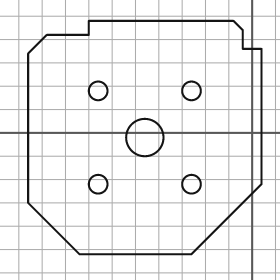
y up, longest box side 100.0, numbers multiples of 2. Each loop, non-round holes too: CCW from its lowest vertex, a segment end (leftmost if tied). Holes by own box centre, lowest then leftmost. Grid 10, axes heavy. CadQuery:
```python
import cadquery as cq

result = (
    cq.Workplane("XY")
    .moveTo(-74.0, -52.0)
    .lineTo(-26.0, -52.0)
    .lineTo(4.0, -22.0)
    .lineTo(4.0, 36.0)
    .lineTo(-4.0, 36.0)
    .lineTo(-4.0, 44.0)
    .lineTo(-8.0, 48.0)
    .lineTo(-70.0, 48.0)
    .lineTo(-70.0, 42.0)
    .lineTo(-88.0, 42.0)
    .lineTo(-96.0, 34.0)
    .lineTo(-96.0, -30.0)
    .close()
    .moveTo(-66.0, -22.0)
    .circle(4.0)
    .moveTo(-26.0, -22.0)
    .circle(4.0)
    .moveTo(-46.0, -2.0)
    .circle(8.0)
    .moveTo(-66.0, 18.0)
    .circle(4.0)
    .moveTo(-26.0, 18.0)
    .circle(4.0)
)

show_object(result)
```